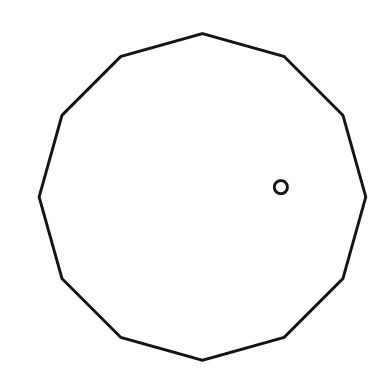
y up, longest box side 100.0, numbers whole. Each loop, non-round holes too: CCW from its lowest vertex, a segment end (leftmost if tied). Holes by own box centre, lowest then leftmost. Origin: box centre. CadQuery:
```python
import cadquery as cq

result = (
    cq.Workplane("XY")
    .moveTo(0.0, -50.0)
    .lineTo(25.0, -43.0)
    .lineTo(43.0, -25.0)
    .lineTo(50.0, 0.0)
    .lineTo(43.0, 25.0)
    .lineTo(25.0, 43.0)
    .lineTo(0.0, 50.0)
    .lineTo(-25.0, 43.0)
    .lineTo(-43.0, 25.0)
    .lineTo(-50.0, 0.0)
    .lineTo(-43.0, -25.0)
    .lineTo(-25.0, -43.0)
    .close()
    .moveTo(24.0, 3.0)
    .circle(2.0)
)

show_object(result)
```